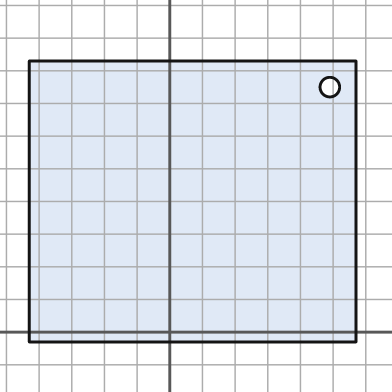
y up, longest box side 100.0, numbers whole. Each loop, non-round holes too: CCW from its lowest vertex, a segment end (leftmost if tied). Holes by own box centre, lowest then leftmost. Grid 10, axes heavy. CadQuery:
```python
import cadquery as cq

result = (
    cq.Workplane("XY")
    .moveTo(-43.0, -3.0)
    .lineTo(57.0, -3.0)
    .lineTo(57.0, 83.0)
    .lineTo(-43.0, 83.0)
    .close()
    .moveTo(49.0, 75.0)
    .circle(3.0)
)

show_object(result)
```